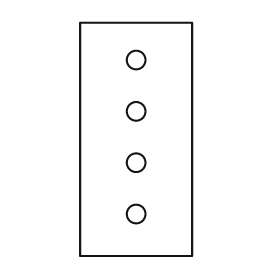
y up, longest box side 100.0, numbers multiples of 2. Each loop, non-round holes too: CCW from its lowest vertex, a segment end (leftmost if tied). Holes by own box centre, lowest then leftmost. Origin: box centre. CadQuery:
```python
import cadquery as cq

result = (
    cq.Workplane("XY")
    .moveTo(-24.0, -50.0)
    .lineTo(24.0, -50.0)
    .lineTo(24.0, 50.0)
    .lineTo(-24.0, 50.0)
    .close()
    .moveTo(0.0, -32.0)
    .circle(4.0)
    .moveTo(0.0, -10.0)
    .circle(4.0)
    .moveTo(0.0, 12.0)
    .circle(4.0)
    .moveTo(0.0, 34.0)
    .circle(4.0)
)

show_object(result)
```